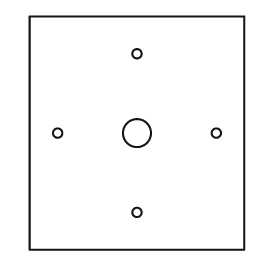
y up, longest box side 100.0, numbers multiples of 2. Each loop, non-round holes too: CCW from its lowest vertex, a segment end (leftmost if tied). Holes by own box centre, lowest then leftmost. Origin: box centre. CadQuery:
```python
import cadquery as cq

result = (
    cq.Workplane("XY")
    .moveTo(-46.0, -50.0)
    .lineTo(46.0, -50.0)
    .lineTo(46.0, 50.0)
    .lineTo(-46.0, 50.0)
    .close()
    .moveTo(0.0, -34.0)
    .circle(2.0)
    .moveTo(-34.0, 0.0)
    .circle(2.0)
    .moveTo(0.0, 0.0)
    .circle(6.0)
    .moveTo(34.0, 0.0)
    .circle(2.0)
    .moveTo(0.0, 34.0)
    .circle(2.0)
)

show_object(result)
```